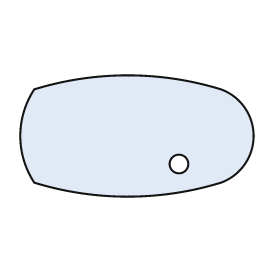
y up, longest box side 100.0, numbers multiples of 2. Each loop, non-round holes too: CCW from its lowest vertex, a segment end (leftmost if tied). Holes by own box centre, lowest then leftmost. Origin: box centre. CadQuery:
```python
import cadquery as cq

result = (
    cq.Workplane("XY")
    .moveTo(-44.0, -20.0)
    .threePointArc((-4.0, -26.0), (36.0, -20.0))
    .threePointArc((50.0, 0.0), (36.0, 20.0))
    .threePointArc((-4.0, 26.0), (-44.0, 20.0))
    .threePointArc((-50.0, 0.0), (-44.0, -20.0))
    .close()
    .moveTo(18.0, -12.0)
    .circle(4.0)
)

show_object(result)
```